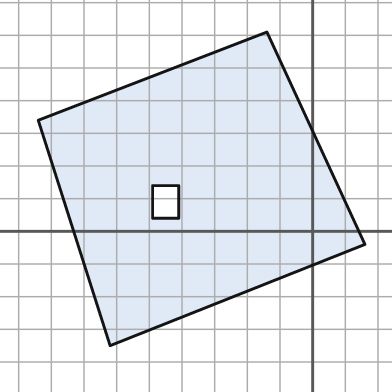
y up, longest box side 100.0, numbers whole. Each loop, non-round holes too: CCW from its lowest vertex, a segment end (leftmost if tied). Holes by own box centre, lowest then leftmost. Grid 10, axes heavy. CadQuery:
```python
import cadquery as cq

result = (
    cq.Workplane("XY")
    .moveTo(-62.0, -35.0)
    .lineTo(16.0, -4.0)
    .lineTo(-14.0, 61.0)
    .lineTo(-84.0, 34.0)
    .close()
    .moveTo(-49.0, 4.0)
    .lineTo(-41.0, 4.0)
    .lineTo(-41.0, 14.0)
    .lineTo(-49.0, 14.0)
    .close()
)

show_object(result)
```